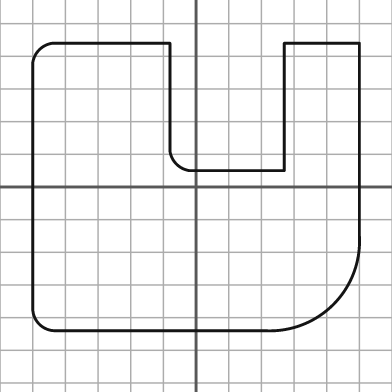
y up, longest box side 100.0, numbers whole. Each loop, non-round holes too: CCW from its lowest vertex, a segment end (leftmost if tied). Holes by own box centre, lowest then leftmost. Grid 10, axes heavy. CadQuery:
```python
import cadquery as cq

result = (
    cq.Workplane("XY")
    .moveTo(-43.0, -44.0)
    .lineTo(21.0, -44.0)
    .threePointArc((42.0, -36.0), (50.0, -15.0))
    .lineTo(50.0, 44.0)
    .lineTo(27.0, 44.0)
    .lineTo(27.0, 5.0)
    .lineTo(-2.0, 5.0)
    .threePointArc((-6.0, 7.0), (-8.0, 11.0))
    .lineTo(-8.0, 44.0)
    .lineTo(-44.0, 44.0)
    .threePointArc((-48.0, 42.0), (-50.0, 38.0))
    .lineTo(-50.0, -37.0)
    .threePointArc((-48.0, -42.0), (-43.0, -44.0))
    .close()
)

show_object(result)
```